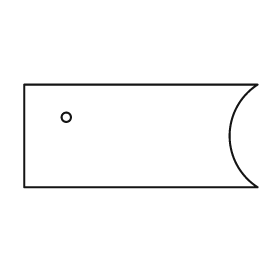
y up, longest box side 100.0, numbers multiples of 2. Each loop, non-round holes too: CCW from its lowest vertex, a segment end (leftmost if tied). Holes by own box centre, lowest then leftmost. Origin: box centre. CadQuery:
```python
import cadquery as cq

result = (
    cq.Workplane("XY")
    .moveTo(-50.0, -22.0)
    .lineTo(50.0, -22.0)
    .threePointArc((38.0, 0.0), (50.0, 22.0))
    .lineTo(-50.0, 22.0)
    .close()
    .moveTo(-32.0, 8.0)
    .circle(2.0)
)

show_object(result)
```